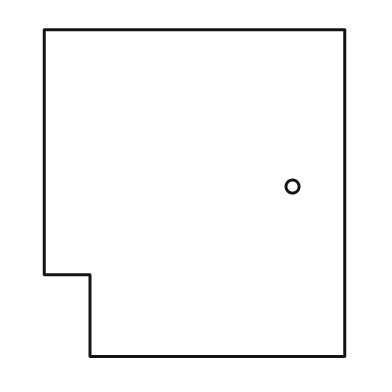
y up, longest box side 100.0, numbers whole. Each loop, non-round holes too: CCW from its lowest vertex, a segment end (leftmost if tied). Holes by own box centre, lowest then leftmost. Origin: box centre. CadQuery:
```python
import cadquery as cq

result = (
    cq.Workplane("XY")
    .moveTo(-32.0, -50.0)
    .lineTo(46.0, -50.0)
    .lineTo(46.0, 50.0)
    .lineTo(-46.0, 50.0)
    .lineTo(-46.0, -25.0)
    .lineTo(-32.0, -25.0)
    .close()
    .moveTo(30.0, 2.0)
    .circle(2.0)
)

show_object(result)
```